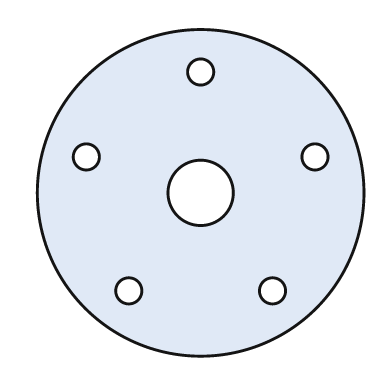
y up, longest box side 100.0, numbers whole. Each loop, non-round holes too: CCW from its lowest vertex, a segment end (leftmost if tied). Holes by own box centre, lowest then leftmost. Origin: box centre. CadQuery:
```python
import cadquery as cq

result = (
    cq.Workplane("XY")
    .moveTo(0.0, 0.0)
    .circle(50.0)
    .moveTo(-22.0, -30.0)
    .circle(4.0)
    .moveTo(22.0, -30.0)
    .circle(4.0)
    .moveTo(0.0, 0.0)
    .circle(10.0)
    .moveTo(-35.0, 11.0)
    .circle(4.0)
    .moveTo(35.0, 11.0)
    .circle(4.0)
    .moveTo(0.0, 37.0)
    .circle(4.0)
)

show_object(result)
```